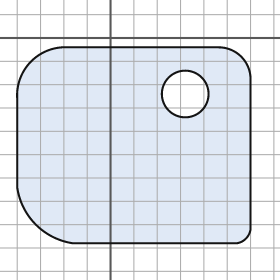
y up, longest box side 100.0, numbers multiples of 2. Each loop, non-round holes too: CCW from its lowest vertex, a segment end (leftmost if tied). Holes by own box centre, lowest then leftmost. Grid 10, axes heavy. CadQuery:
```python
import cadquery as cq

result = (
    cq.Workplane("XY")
    .moveTo(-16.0, -88.0)
    .lineTo(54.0, -88.0)
    .threePointArc((58.0, -86.0), (60.0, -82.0))
    .lineTo(60.0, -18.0)
    .threePointArc((56.0, -8.0), (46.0, -4.0))
    .lineTo(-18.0, -4.0)
    .threePointArc((-34.0, -10.0), (-40.0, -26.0))
    .lineTo(-40.0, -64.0)
    .threePointArc((-32.0, -80.0), (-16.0, -88.0))
    .close()
    .moveTo(32.0, -24.0)
    .circle(10.0)
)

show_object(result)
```